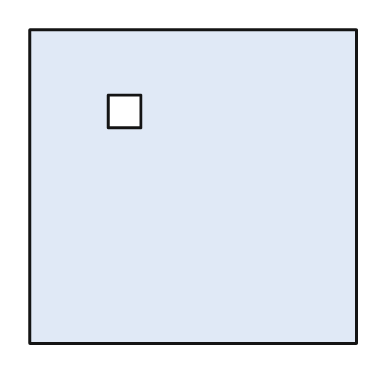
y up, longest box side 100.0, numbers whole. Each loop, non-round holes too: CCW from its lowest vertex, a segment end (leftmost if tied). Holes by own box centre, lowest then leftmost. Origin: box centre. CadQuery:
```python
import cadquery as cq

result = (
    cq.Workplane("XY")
    .moveTo(-50.0, -48.0)
    .lineTo(50.0, -48.0)
    .lineTo(50.0, 48.0)
    .lineTo(-50.0, 48.0)
    .close()
    .moveTo(-26.0, 18.0)
    .lineTo(-16.0, 18.0)
    .lineTo(-16.0, 28.0)
    .lineTo(-26.0, 28.0)
    .close()
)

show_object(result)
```